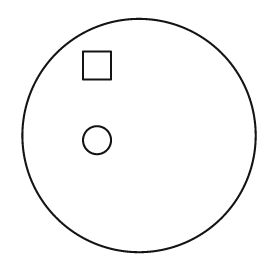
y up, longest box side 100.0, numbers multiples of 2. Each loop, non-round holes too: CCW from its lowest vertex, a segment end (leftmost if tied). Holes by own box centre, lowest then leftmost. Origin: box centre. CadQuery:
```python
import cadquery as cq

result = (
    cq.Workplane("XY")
    .moveTo(0.0, 0.0)
    .circle(50.0)
    .moveTo(-18.0, -2.0)
    .circle(6.0)
    .moveTo(-24.0, 24.0)
    .lineTo(-12.0, 24.0)
    .lineTo(-12.0, 36.0)
    .lineTo(-24.0, 36.0)
    .close()
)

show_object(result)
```